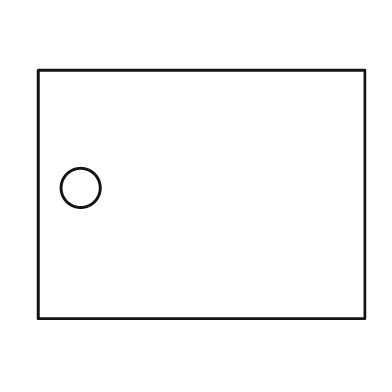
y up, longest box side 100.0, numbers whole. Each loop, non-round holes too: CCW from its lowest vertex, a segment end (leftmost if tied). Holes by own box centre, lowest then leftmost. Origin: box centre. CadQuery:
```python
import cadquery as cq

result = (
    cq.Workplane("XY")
    .moveTo(-50.0, -38.0)
    .lineTo(50.0, -38.0)
    .lineTo(50.0, 38.0)
    .lineTo(-50.0, 38.0)
    .close()
    .moveTo(-37.0, 2.0)
    .circle(6.0)
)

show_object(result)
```